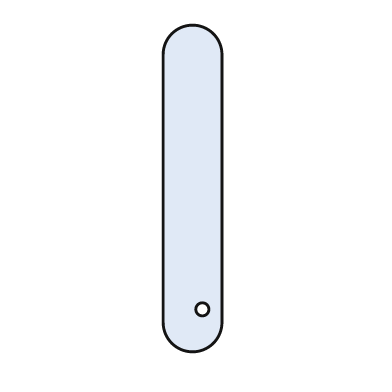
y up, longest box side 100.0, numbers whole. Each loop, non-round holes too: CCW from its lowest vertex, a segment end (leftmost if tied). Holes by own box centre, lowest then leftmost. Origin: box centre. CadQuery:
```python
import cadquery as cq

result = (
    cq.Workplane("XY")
    .moveTo(-9.0, -41.0)
    .threePointArc((0.0, -50.0), (9.0, -41.0))
    .lineTo(9.0, 41.0)
    .threePointArc((0.0, 50.0), (-9.0, 41.0))
    .close()
    .moveTo(3.0, -37.0)
    .circle(2.0)
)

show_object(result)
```